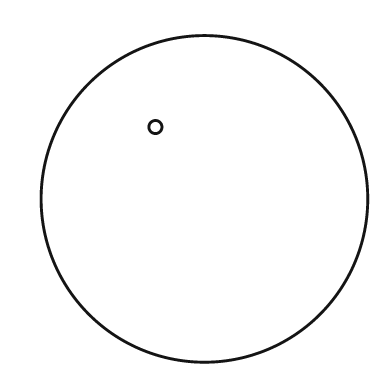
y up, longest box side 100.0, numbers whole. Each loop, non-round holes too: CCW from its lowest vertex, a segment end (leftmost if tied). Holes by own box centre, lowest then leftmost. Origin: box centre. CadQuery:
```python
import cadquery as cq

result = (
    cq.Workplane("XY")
    .moveTo(0.0, 0.0)
    .circle(50.0)
    .moveTo(-15.0, 22.0)
    .circle(2.0)
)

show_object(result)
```